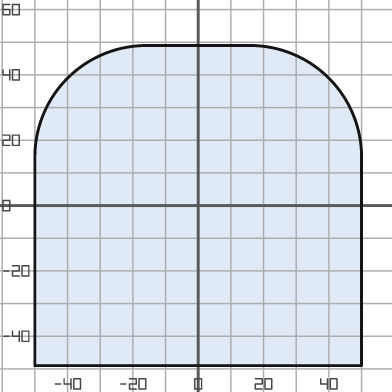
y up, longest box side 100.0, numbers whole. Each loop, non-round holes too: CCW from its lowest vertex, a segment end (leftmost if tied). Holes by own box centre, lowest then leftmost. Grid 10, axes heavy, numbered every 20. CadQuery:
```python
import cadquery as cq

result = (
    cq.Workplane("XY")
    .moveTo(-50.0, -49.0)
    .lineTo(50.0, -49.0)
    .lineTo(50.0, 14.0)
    .threePointArc((40.0, 39.0), (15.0, 49.0))
    .lineTo(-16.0, 49.0)
    .threePointArc((-40.0, 39.0), (-50.0, 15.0))
    .close()
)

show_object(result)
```